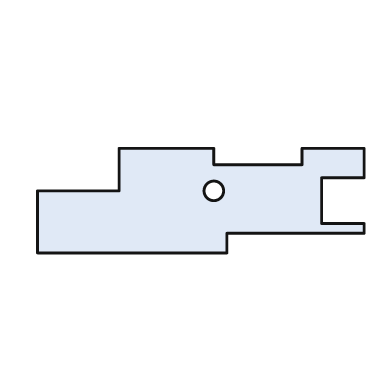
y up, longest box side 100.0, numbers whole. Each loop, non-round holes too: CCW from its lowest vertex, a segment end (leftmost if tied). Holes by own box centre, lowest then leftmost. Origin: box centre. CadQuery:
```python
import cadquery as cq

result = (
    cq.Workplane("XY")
    .moveTo(-50.0, -16.0)
    .lineTo(8.0, -16.0)
    .lineTo(8.0, -10.0)
    .lineTo(50.0, -10.0)
    .lineTo(50.0, -7.0)
    .lineTo(37.0, -7.0)
    .lineTo(37.0, 7.0)
    .lineTo(50.0, 7.0)
    .lineTo(50.0, 16.0)
    .lineTo(31.0, 16.0)
    .lineTo(31.0, 11.0)
    .lineTo(4.0, 11.0)
    .lineTo(4.0, 16.0)
    .lineTo(-25.0, 16.0)
    .lineTo(-25.0, 3.0)
    .lineTo(-50.0, 3.0)
    .close()
    .moveTo(4.0, 3.0)
    .circle(3.0)
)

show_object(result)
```